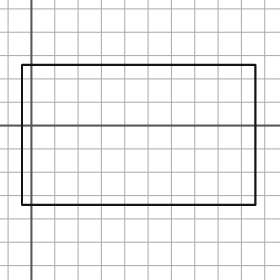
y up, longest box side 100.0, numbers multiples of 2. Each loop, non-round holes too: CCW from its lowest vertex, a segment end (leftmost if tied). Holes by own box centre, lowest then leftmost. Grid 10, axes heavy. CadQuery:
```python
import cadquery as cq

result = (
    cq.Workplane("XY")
    .moveTo(-4.0, -34.0)
    .lineTo(96.0, -34.0)
    .lineTo(96.0, 26.0)
    .lineTo(-4.0, 26.0)
    .close()
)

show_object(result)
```